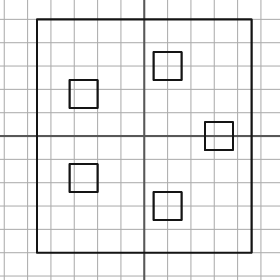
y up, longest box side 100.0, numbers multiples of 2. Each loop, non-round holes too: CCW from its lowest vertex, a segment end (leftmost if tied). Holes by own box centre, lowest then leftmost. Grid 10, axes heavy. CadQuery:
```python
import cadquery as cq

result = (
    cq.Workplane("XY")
    .moveTo(-46.0, -50.0)
    .lineTo(46.0, -50.0)
    .lineTo(46.0, 50.0)
    .lineTo(-46.0, 50.0)
    .close()
    .moveTo(4.0, -36.0)
    .lineTo(16.0, -36.0)
    .lineTo(16.0, -24.0)
    .lineTo(4.0, -24.0)
    .close()
    .moveTo(-32.0, -24.0)
    .lineTo(-20.0, -24.0)
    .lineTo(-20.0, -12.0)
    .lineTo(-32.0, -12.0)
    .close()
    .moveTo(26.0, -6.0)
    .lineTo(38.0, -6.0)
    .lineTo(38.0, 6.0)
    .lineTo(26.0, 6.0)
    .close()
    .moveTo(-32.0, 12.0)
    .lineTo(-20.0, 12.0)
    .lineTo(-20.0, 24.0)
    .lineTo(-32.0, 24.0)
    .close()
    .moveTo(4.0, 24.0)
    .lineTo(16.0, 24.0)
    .lineTo(16.0, 36.0)
    .lineTo(4.0, 36.0)
    .close()
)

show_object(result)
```